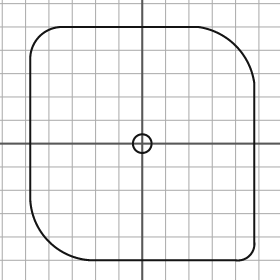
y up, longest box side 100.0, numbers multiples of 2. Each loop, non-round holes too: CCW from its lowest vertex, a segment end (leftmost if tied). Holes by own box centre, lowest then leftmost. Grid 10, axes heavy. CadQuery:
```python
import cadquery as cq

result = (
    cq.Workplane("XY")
    .moveTo(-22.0, -50.0)
    .lineTo(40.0, -50.0)
    .threePointArc((46.0, -48.0), (48.0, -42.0))
    .lineTo(48.0, 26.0)
    .threePointArc((40.0, 42.0), (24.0, 50.0))
    .lineTo(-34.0, 50.0)
    .threePointArc((-44.0, 46.0), (-48.0, 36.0))
    .lineTo(-48.0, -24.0)
    .threePointArc((-40.0, -42.0), (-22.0, -50.0))
    .close()
    .moveTo(0.0, 0.0)
    .circle(4.0)
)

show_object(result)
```